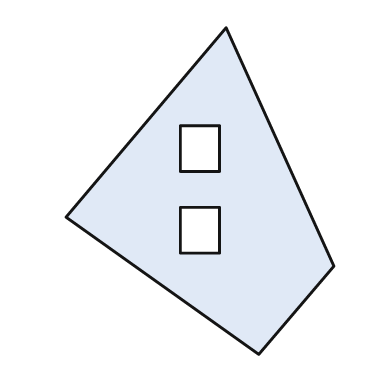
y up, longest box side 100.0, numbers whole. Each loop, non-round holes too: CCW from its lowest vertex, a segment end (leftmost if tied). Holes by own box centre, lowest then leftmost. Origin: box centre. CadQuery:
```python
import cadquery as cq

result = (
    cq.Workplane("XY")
    .moveTo(18.0, -50.0)
    .lineTo(41.0, -23.0)
    .lineTo(8.0, 50.0)
    .lineTo(-41.0, -8.0)
    .close()
    .moveTo(-6.0, -19.0)
    .lineTo(6.0, -19.0)
    .lineTo(6.0, -5.0)
    .lineTo(-6.0, -5.0)
    .close()
    .moveTo(-6.0, 6.0)
    .lineTo(6.0, 6.0)
    .lineTo(6.0, 20.0)
    .lineTo(-6.0, 20.0)
    .close()
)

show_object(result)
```